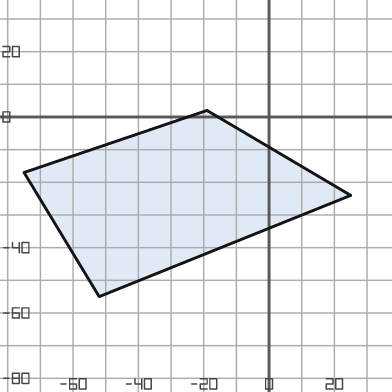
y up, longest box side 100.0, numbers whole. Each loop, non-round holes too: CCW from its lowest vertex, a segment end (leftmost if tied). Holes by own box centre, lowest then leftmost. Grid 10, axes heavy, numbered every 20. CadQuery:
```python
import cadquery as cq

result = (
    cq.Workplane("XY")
    .moveTo(-52.0, -55.0)
    .lineTo(25.0, -24.0)
    .lineTo(-19.0, 2.0)
    .lineTo(-75.0, -17.0)
    .close()
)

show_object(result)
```